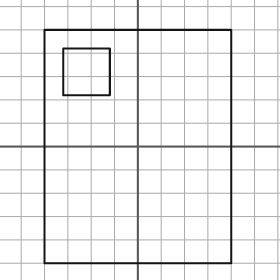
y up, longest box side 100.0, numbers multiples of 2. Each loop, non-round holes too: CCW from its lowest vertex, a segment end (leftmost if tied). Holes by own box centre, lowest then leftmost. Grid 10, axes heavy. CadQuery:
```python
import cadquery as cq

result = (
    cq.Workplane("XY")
    .moveTo(-40.0, -50.0)
    .lineTo(40.0, -50.0)
    .lineTo(40.0, 50.0)
    .lineTo(-40.0, 50.0)
    .close()
    .moveTo(-32.0, 22.0)
    .lineTo(-12.0, 22.0)
    .lineTo(-12.0, 42.0)
    .lineTo(-32.0, 42.0)
    .close()
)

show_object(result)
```